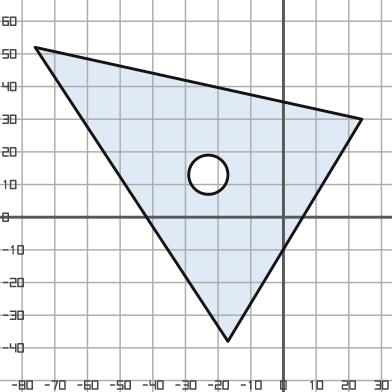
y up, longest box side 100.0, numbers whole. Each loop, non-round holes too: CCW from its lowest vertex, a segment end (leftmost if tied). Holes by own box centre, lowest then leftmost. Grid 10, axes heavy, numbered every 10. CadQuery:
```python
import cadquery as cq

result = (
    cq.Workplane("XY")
    .moveTo(-17.0, -38.0)
    .lineTo(24.0, 30.0)
    .lineTo(-76.0, 52.0)
    .close()
    .moveTo(-23.0, 13.0)
    .circle(6.0)
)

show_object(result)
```